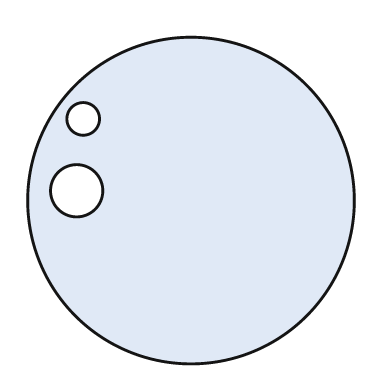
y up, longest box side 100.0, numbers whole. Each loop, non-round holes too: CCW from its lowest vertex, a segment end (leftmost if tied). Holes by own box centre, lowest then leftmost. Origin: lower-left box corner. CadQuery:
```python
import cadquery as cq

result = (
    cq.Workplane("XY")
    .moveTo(50.0, 50.0)
    .circle(50.0)
    .moveTo(15.0, 53.0)
    .circle(8.0)
    .moveTo(17.0, 75.0)
    .circle(5.0)
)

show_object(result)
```